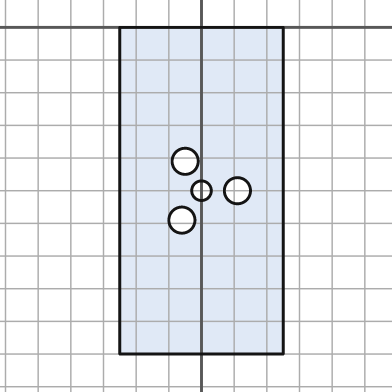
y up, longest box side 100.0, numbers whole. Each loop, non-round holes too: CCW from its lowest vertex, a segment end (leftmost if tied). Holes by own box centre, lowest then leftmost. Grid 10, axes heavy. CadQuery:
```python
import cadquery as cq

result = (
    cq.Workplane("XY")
    .moveTo(-25.0, -100.0)
    .lineTo(25.0, -100.0)
    .lineTo(25.0, 0.0)
    .lineTo(-25.0, 0.0)
    .close()
    .moveTo(-6.0, -59.0)
    .circle(4.0)
    .moveTo(0.0, -50.0)
    .circle(3.0)
    .moveTo(11.0, -50.0)
    .circle(4.0)
    .moveTo(-5.0, -41.0)
    .circle(4.0)
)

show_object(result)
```